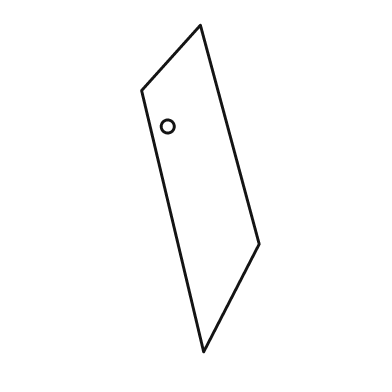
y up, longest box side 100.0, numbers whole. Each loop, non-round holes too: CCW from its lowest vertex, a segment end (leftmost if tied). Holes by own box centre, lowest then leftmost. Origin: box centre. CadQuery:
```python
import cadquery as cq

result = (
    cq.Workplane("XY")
    .moveTo(1.0, -50.0)
    .lineTo(18.0, -17.0)
    .lineTo(0.0, 50.0)
    .lineTo(-18.0, 30.0)
    .close()
    .moveTo(-10.0, 19.0)
    .circle(2.0)
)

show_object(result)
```